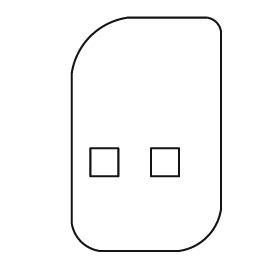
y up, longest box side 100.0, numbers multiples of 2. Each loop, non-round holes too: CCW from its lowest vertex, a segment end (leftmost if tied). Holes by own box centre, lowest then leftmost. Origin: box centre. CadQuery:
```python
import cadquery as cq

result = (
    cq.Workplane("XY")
    .moveTo(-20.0, -50.0)
    .lineTo(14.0, -50.0)
    .threePointArc((26.0, -44.0), (32.0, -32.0))
    .lineTo(32.0, 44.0)
    .threePointArc((30.0, 48.0), (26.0, 50.0))
    .lineTo(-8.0, 50.0)
    .threePointArc((-24.0, 42.0), (-32.0, 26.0))
    .lineTo(-32.0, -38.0)
    .threePointArc((-28.0, -46.0), (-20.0, -50.0))
    .close()
    .moveTo(-24.0, -18.0)
    .lineTo(-12.0, -18.0)
    .lineTo(-12.0, -6.0)
    .lineTo(-24.0, -6.0)
    .close()
    .moveTo(2.0, -18.0)
    .lineTo(14.0, -18.0)
    .lineTo(14.0, -6.0)
    .lineTo(2.0, -6.0)
    .close()
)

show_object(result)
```